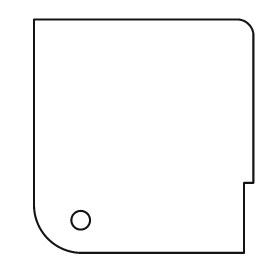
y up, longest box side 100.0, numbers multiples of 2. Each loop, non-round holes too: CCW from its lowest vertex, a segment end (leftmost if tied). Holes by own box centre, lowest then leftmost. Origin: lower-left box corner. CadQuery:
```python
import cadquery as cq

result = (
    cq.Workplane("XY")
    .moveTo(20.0, 0.0)
    .lineTo(90.0, 0.0)
    .lineTo(90.0, 30.0)
    .lineTo(94.0, 30.0)
    .lineTo(94.0, 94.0)
    .threePointArc((92.0, 98.0), (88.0, 100.0))
    .lineTo(0.0, 100.0)
    .lineTo(0.0, 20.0)
    .threePointArc((6.0, 6.0), (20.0, 0.0))
    .close()
    .moveTo(20.0, 14.0)
    .circle(4.0)
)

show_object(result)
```